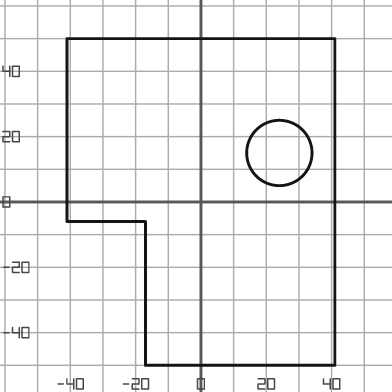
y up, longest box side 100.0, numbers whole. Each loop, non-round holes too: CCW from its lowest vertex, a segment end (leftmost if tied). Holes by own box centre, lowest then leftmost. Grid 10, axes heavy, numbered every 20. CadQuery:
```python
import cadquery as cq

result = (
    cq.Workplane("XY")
    .moveTo(-17.0, -50.0)
    .lineTo(41.0, -50.0)
    .lineTo(41.0, 50.0)
    .lineTo(-41.0, 50.0)
    .lineTo(-41.0, -6.0)
    .lineTo(-17.0, -6.0)
    .close()
    .moveTo(24.0, 15.0)
    .circle(10.0)
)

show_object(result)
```